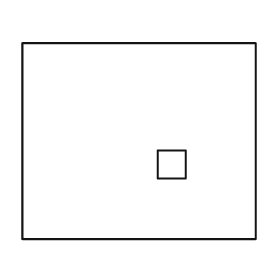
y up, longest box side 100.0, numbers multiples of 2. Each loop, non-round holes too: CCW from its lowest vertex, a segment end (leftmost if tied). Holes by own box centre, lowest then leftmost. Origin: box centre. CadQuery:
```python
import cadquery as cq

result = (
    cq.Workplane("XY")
    .moveTo(-50.0, -42.0)
    .lineTo(50.0, -42.0)
    .lineTo(50.0, 42.0)
    .lineTo(-50.0, 42.0)
    .close()
    .moveTo(8.0, -16.0)
    .lineTo(20.0, -16.0)
    .lineTo(20.0, -4.0)
    .lineTo(8.0, -4.0)
    .close()
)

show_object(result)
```